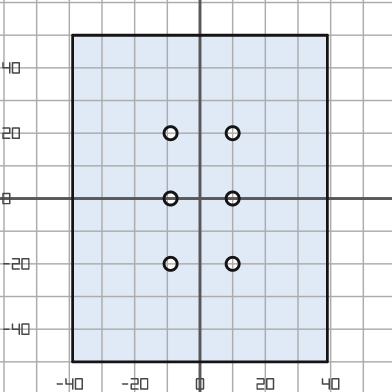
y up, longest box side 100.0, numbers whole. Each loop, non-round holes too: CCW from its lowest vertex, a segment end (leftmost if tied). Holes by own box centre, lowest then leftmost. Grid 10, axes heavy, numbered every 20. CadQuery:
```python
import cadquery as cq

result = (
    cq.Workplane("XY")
    .moveTo(-39.0, -50.0)
    .lineTo(39.0, -50.0)
    .lineTo(39.0, 50.0)
    .lineTo(-39.0, 50.0)
    .close()
    .moveTo(-9.0, -20.0)
    .circle(2.0)
    .moveTo(10.0, -20.0)
    .circle(2.0)
    .moveTo(-9.0, 0.0)
    .circle(2.0)
    .moveTo(10.0, 0.0)
    .circle(2.0)
    .moveTo(-9.0, 20.0)
    .circle(2.0)
    .moveTo(10.0, 20.0)
    .circle(2.0)
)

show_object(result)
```